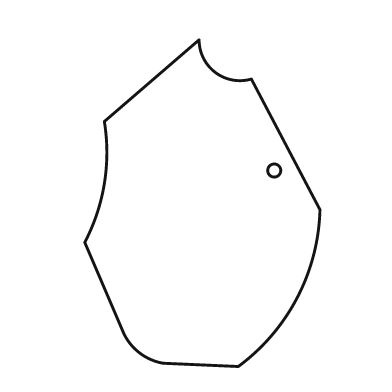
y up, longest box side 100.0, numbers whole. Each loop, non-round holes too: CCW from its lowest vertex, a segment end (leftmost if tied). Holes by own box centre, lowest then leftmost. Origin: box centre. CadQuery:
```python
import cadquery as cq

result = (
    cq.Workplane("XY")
    .moveTo(11.0, -50.0)
    .threePointArc((29.0, -29.0), (36.0, -2.0))
    .lineTo(15.0, 38.0)
    .threePointArc((4.0, 40.0), (-1.0, 50.0))
    .lineTo(-30.0, 25.0)
    .threePointArc((-30.0, 6.0), (-36.0, -12.0))
    .lineTo(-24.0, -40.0)
    .threePointArc((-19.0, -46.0), (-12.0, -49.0))
    .close()
    .moveTo(22.0, 10.0)
    .circle(2.0)
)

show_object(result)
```